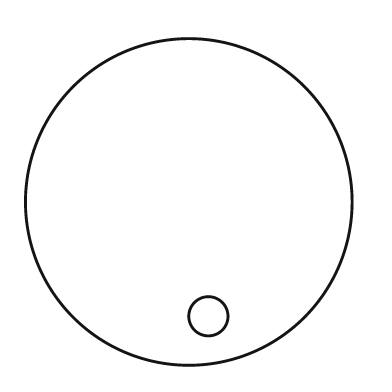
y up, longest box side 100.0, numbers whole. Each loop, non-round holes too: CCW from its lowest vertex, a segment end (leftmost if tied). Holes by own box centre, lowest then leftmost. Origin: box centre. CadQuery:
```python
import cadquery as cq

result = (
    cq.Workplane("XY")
    .moveTo(0.0, 0.0)
    .circle(50.0)
    .moveTo(6.0, -35.0)
    .circle(6.0)
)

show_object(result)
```